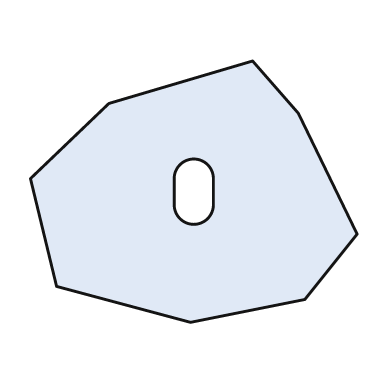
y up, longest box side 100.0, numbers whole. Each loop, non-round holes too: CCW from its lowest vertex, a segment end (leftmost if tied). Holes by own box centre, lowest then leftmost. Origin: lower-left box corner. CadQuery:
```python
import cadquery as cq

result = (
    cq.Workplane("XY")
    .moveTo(49.0, 0.0)
    .lineTo(84.0, 7.0)
    .lineTo(100.0, 27.0)
    .lineTo(82.0, 64.0)
    .lineTo(68.0, 80.0)
    .lineTo(24.0, 67.0)
    .lineTo(0.0, 44.0)
    .lineTo(8.0, 11.0)
    .close()
    .moveTo(44.0, 36.0)
    .threePointArc((50.0, 30.0), (56.0, 36.0))
    .lineTo(56.0, 44.0)
    .threePointArc((50.0, 50.0), (44.0, 44.0))
    .close()
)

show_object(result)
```